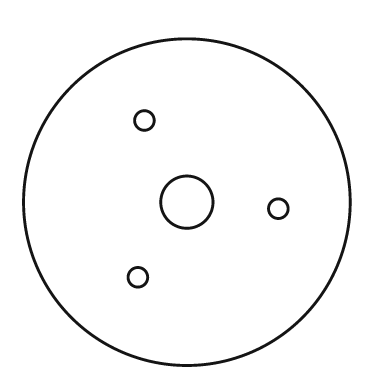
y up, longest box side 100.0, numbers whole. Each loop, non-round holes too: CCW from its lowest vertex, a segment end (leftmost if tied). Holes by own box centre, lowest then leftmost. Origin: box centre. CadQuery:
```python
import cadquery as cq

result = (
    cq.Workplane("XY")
    .moveTo(0.0, 0.0)
    .circle(50.0)
    .moveTo(-15.0, -23.0)
    .circle(3.0)
    .moveTo(28.0, -2.0)
    .circle(3.0)
    .moveTo(0.0, 0.0)
    .circle(8.0)
    .moveTo(-13.0, 25.0)
    .circle(3.0)
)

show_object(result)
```